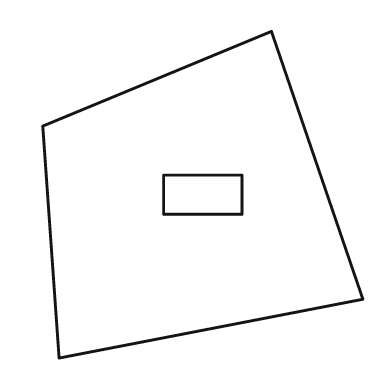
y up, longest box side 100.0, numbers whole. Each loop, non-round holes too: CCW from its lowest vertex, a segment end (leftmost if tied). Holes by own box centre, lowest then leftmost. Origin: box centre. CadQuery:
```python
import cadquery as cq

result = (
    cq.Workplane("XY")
    .moveTo(-44.0, -50.0)
    .lineTo(49.0, -32.0)
    .lineTo(21.0, 50.0)
    .lineTo(-49.0, 21.0)
    .close()
    .moveTo(-12.0, -6.0)
    .lineTo(12.0, -6.0)
    .lineTo(12.0, 6.0)
    .lineTo(-12.0, 6.0)
    .close()
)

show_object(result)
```